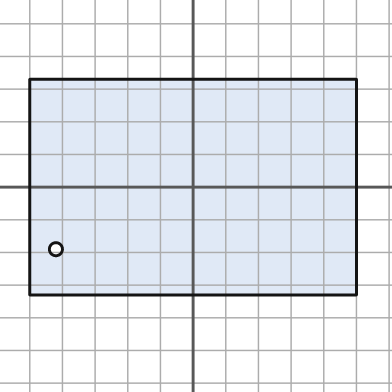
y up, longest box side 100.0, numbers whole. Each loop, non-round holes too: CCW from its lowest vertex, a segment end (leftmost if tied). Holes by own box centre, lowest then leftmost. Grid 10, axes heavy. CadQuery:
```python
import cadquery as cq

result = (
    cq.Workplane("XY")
    .moveTo(-50.0, -33.0)
    .lineTo(50.0, -33.0)
    .lineTo(50.0, 33.0)
    .lineTo(-50.0, 33.0)
    .close()
    .moveTo(-42.0, -19.0)
    .circle(2.0)
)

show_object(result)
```